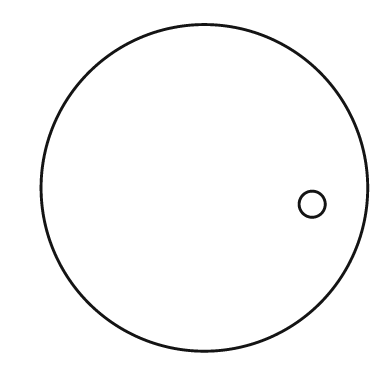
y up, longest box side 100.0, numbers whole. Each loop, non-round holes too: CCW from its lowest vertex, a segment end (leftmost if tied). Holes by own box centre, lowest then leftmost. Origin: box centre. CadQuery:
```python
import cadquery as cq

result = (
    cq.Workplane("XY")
    .moveTo(0.0, 0.0)
    .circle(50.0)
    .moveTo(33.0, -5.0)
    .circle(4.0)
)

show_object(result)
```